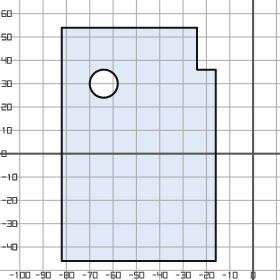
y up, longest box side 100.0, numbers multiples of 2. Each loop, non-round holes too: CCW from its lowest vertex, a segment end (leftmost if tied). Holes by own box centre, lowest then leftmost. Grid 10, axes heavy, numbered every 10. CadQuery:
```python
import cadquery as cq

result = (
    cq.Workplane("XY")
    .moveTo(-82.0, -46.0)
    .lineTo(-16.0, -46.0)
    .lineTo(-16.0, 36.0)
    .lineTo(-24.0, 36.0)
    .lineTo(-24.0, 54.0)
    .lineTo(-82.0, 54.0)
    .close()
    .moveTo(-64.0, 30.0)
    .circle(6.0)
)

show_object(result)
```